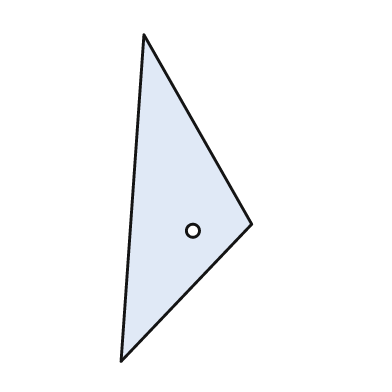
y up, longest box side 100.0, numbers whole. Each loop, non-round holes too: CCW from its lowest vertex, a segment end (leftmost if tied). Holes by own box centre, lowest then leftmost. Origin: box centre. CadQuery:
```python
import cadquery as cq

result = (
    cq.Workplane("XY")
    .moveTo(-20.0, -50.0)
    .lineTo(20.0, -8.0)
    .lineTo(-13.0, 50.0)
    .close()
    .moveTo(2.0, -10.0)
    .circle(2.0)
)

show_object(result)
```